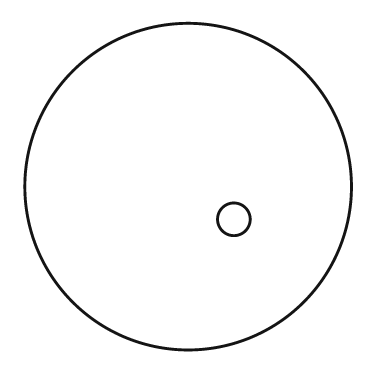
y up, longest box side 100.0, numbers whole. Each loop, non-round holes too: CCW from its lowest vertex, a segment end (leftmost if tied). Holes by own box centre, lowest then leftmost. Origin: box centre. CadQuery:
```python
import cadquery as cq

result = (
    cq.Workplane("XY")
    .moveTo(0.0, 0.0)
    .circle(50.0)
    .moveTo(14.0, -10.0)
    .circle(5.0)
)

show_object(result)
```